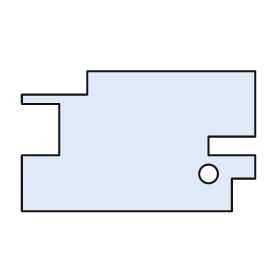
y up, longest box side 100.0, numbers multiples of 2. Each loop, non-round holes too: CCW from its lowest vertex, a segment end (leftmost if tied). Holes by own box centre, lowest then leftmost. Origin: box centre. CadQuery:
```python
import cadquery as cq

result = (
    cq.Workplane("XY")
    .moveTo(-50.0, -30.0)
    .lineTo(40.0, -30.0)
    .lineTo(40.0, -16.0)
    .lineTo(50.0, -16.0)
    .lineTo(50.0, -6.0)
    .lineTo(30.0, -6.0)
    .lineTo(30.0, 2.0)
    .lineTo(50.0, 2.0)
    .lineTo(50.0, 30.0)
    .lineTo(-22.0, 30.0)
    .lineTo(-22.0, 20.0)
    .lineTo(-50.0, 20.0)
    .lineTo(-50.0, 16.0)
    .lineTo(-34.0, 16.0)
    .lineTo(-34.0, -6.0)
    .lineTo(-50.0, -6.0)
    .close()
    .moveTo(30.0, -14.0)
    .circle(4.0)
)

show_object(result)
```